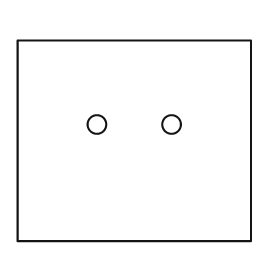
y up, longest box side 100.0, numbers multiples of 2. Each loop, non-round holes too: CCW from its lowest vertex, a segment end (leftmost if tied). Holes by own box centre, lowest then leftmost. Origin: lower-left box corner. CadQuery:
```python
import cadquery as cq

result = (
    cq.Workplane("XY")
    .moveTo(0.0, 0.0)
    .lineTo(100.0, 0.0)
    .lineTo(100.0, 86.0)
    .lineTo(0.0, 86.0)
    .close()
    .moveTo(34.0, 50.0)
    .circle(4.0)
    .moveTo(66.0, 50.0)
    .circle(4.0)
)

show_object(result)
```